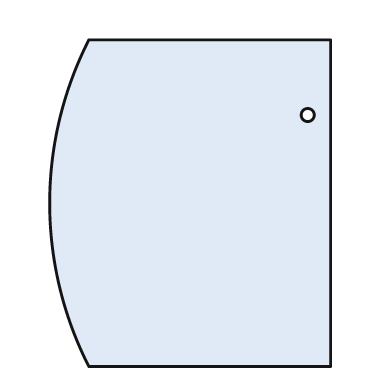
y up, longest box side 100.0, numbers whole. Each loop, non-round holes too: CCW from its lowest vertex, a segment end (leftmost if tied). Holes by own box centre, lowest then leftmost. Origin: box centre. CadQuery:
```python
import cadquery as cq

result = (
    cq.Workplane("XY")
    .moveTo(-31.0, -50.0)
    .lineTo(43.0, -50.0)
    .lineTo(43.0, 50.0)
    .lineTo(-31.0, 50.0)
    .threePointArc((-43.0, 0.0), (-31.0, -50.0))
    .close()
    .moveTo(36.0, 27.0)
    .circle(2.0)
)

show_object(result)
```